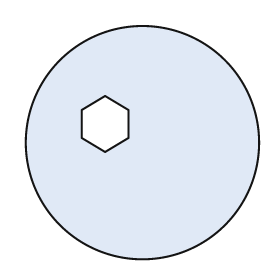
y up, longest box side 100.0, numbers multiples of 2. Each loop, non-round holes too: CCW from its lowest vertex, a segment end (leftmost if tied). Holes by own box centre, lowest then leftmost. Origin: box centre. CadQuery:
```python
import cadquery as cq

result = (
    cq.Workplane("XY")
    .moveTo(0.0, 0.0)
    .circle(50.0)
    .moveTo(-16.0, -4.0)
    .lineTo(-6.0, 2.0)
    .lineTo(-6.0, 14.0)
    .lineTo(-16.0, 20.0)
    .lineTo(-26.0, 14.0)
    .lineTo(-26.0, 2.0)
    .close()
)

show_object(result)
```